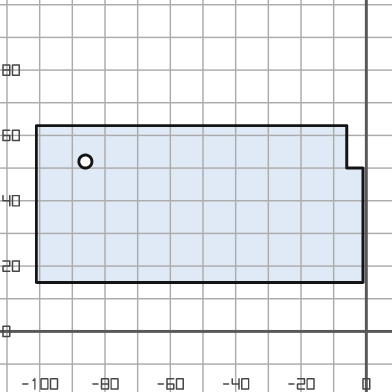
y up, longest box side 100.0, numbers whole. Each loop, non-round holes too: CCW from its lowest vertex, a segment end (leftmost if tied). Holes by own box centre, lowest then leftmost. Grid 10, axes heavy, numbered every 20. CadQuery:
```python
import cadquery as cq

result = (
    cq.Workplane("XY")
    .moveTo(-101.0, 15.0)
    .lineTo(-1.0, 15.0)
    .lineTo(-1.0, 50.0)
    .lineTo(-6.0, 50.0)
    .lineTo(-6.0, 63.0)
    .lineTo(-101.0, 63.0)
    .close()
    .moveTo(-86.0, 52.0)
    .circle(2.0)
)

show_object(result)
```